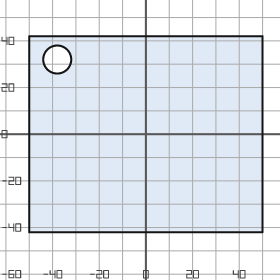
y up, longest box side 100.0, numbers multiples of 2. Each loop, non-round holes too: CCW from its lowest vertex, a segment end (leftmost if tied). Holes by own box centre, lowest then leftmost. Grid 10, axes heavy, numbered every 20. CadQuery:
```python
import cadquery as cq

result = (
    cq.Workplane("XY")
    .moveTo(-50.0, -42.0)
    .lineTo(50.0, -42.0)
    .lineTo(50.0, 42.0)
    .lineTo(-50.0, 42.0)
    .close()
    .moveTo(-38.0, 32.0)
    .circle(6.0)
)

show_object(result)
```